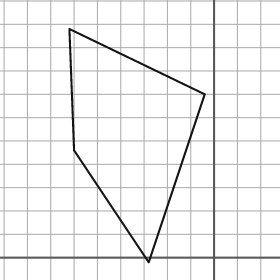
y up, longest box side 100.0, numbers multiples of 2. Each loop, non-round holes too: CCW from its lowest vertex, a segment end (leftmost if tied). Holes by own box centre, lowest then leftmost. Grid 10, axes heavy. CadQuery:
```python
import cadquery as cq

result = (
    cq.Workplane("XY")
    .moveTo(-28.0, -2.0)
    .lineTo(-4.0, 70.0)
    .lineTo(-62.0, 98.0)
    .lineTo(-60.0, 46.0)
    .close()
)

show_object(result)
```